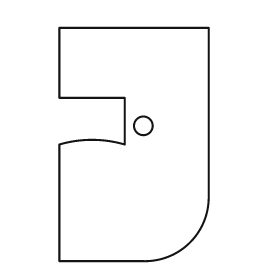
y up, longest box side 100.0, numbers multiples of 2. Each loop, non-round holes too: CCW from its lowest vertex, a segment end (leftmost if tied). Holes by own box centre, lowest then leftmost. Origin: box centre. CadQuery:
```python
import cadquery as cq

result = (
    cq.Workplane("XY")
    .moveTo(-32.0, -50.0)
    .lineTo(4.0, -50.0)
    .threePointArc((24.0, -42.0), (32.0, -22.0))
    .lineTo(32.0, 50.0)
    .lineTo(-32.0, 50.0)
    .lineTo(-32.0, 20.0)
    .lineTo(-4.0, 20.0)
    .lineTo(-4.0, 0.0)
    .threePointArc((-18.0, 2.0), (-32.0, 0.0))
    .close()
    .moveTo(4.0, 8.0)
    .circle(4.0)
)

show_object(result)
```